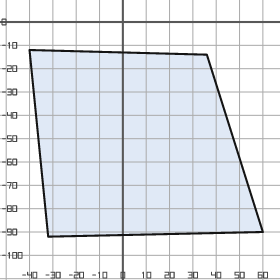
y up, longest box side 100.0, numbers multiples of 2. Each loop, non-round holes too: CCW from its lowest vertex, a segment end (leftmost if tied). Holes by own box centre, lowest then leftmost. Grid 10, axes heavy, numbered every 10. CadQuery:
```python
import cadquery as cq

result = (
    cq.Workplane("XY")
    .moveTo(-32.0, -92.0)
    .lineTo(60.0, -90.0)
    .lineTo(36.0, -14.0)
    .lineTo(-40.0, -12.0)
    .close()
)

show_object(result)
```